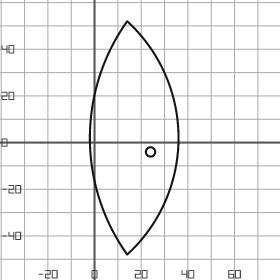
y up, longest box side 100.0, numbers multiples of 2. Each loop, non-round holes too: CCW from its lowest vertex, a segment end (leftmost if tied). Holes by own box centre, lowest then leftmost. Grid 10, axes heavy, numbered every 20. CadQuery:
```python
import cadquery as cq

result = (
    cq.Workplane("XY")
    .moveTo(14.0, -48.0)
    .threePointArc((36.0, 2.0), (14.0, 52.0))
    .threePointArc((-2.0, 2.0), (14.0, -48.0))
    .close()
    .moveTo(24.0, -4.0)
    .circle(2.0)
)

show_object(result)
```